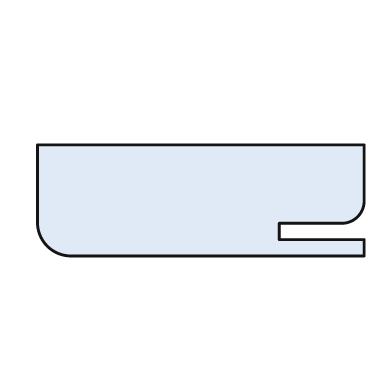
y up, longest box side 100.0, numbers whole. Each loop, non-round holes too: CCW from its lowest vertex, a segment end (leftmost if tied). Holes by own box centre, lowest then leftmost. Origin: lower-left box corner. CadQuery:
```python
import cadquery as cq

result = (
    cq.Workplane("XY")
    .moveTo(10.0, 0.0)
    .lineTo(100.0, 0.0)
    .lineTo(100.0, 5.0)
    .lineTo(74.0, 5.0)
    .lineTo(74.0, 10.0)
    .lineTo(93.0, 10.0)
    .threePointArc((98.0, 12.0), (100.0, 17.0))
    .lineTo(100.0, 34.0)
    .lineTo(0.0, 34.0)
    .lineTo(0.0, 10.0)
    .threePointArc((3.0, 3.0), (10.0, 0.0))
    .close()
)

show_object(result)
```